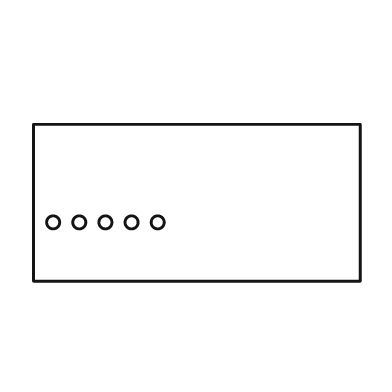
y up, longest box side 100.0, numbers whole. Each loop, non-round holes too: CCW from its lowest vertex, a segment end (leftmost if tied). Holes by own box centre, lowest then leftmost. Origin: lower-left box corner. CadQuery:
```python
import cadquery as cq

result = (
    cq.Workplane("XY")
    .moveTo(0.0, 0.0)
    .lineTo(100.0, 0.0)
    .lineTo(100.0, 48.0)
    .lineTo(0.0, 48.0)
    .close()
    .moveTo(6.0, 18.0)
    .circle(2.0)
    .moveTo(14.0, 18.0)
    .circle(2.0)
    .moveTo(22.0, 18.0)
    .circle(2.0)
    .moveTo(30.0, 18.0)
    .circle(2.0)
    .moveTo(38.0, 18.0)
    .circle(2.0)
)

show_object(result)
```